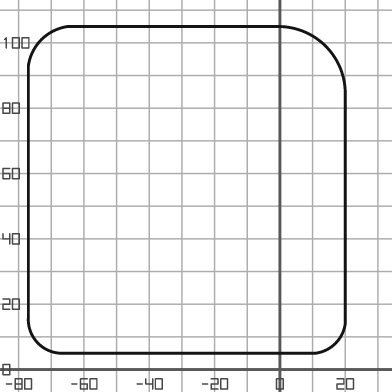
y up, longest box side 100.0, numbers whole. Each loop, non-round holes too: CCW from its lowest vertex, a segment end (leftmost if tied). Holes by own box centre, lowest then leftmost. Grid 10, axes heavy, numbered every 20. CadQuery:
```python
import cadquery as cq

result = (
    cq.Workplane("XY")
    .moveTo(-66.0, 5.0)
    .lineTo(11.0, 5.0)
    .threePointArc((17.0, 8.0), (20.0, 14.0))
    .lineTo(20.0, 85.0)
    .threePointArc((14.0, 99.0), (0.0, 105.0))
    .lineTo(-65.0, 105.0)
    .threePointArc((-73.0, 101.0), (-77.0, 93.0))
    .lineTo(-77.0, 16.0)
    .threePointArc((-74.0, 8.0), (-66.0, 5.0))
    .close()
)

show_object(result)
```